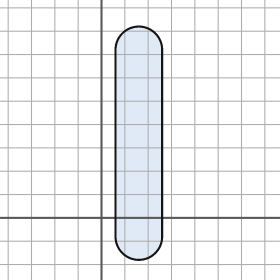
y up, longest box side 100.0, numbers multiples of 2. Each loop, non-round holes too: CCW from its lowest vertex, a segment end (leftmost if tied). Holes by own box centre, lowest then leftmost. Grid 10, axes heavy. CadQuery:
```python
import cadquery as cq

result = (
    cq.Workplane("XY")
    .moveTo(6.0, -8.0)
    .threePointArc((16.0, -18.0), (26.0, -8.0))
    .lineTo(26.0, 72.0)
    .threePointArc((16.0, 82.0), (6.0, 72.0))
    .close()
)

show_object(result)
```